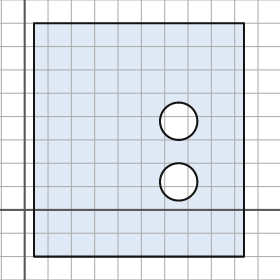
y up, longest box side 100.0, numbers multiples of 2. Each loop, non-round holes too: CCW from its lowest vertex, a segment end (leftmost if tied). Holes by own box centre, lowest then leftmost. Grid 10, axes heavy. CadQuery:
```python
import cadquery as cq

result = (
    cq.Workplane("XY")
    .moveTo(4.0, -20.0)
    .lineTo(94.0, -20.0)
    .lineTo(94.0, 80.0)
    .lineTo(4.0, 80.0)
    .close()
    .moveTo(66.0, 12.0)
    .circle(8.0)
    .moveTo(66.0, 38.0)
    .circle(8.0)
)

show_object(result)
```